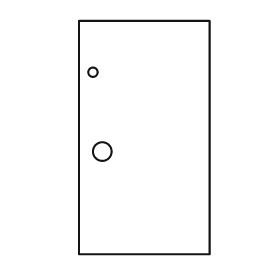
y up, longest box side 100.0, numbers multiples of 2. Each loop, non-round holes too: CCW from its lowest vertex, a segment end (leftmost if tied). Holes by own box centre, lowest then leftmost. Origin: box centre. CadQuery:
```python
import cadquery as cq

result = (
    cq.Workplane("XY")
    .moveTo(-28.0, -50.0)
    .lineTo(28.0, -50.0)
    .lineTo(28.0, 50.0)
    .lineTo(-28.0, 50.0)
    .close()
    .moveTo(-18.0, -6.0)
    .circle(4.0)
    .moveTo(-22.0, 28.0)
    .circle(2.0)
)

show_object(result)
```